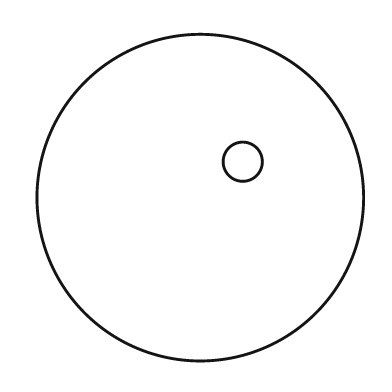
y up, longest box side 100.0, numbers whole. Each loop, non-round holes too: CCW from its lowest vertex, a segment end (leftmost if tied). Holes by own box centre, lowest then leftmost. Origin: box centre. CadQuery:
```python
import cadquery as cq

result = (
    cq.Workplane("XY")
    .moveTo(0.0, 0.0)
    .circle(50.0)
    .moveTo(13.0, 11.0)
    .circle(6.0)
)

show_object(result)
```